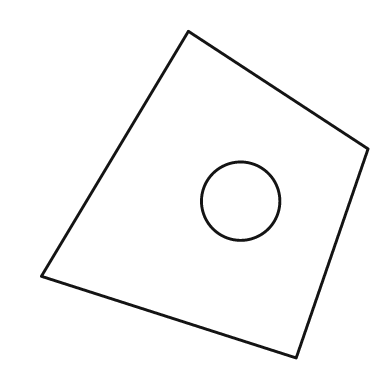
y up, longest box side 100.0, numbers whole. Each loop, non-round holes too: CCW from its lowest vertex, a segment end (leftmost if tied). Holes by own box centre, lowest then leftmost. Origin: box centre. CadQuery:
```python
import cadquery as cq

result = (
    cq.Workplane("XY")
    .moveTo(28.0, -50.0)
    .lineTo(50.0, 14.0)
    .lineTo(-5.0, 50.0)
    .lineTo(-50.0, -25.0)
    .close()
    .moveTo(11.0, -2.0)
    .circle(12.0)
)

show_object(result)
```